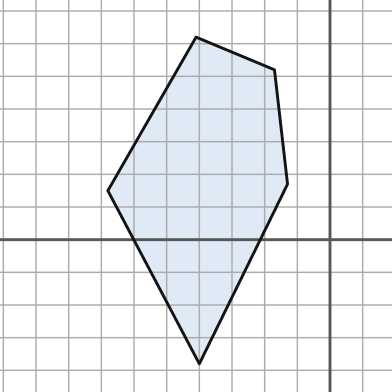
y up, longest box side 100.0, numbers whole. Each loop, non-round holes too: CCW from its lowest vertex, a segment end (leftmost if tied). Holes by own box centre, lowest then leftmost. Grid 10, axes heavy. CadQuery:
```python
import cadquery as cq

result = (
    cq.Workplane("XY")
    .moveTo(-40.0, -38.0)
    .lineTo(-13.0, 17.0)
    .lineTo(-17.0, 52.0)
    .lineTo(-41.0, 62.0)
    .lineTo(-68.0, 15.0)
    .close()
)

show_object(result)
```